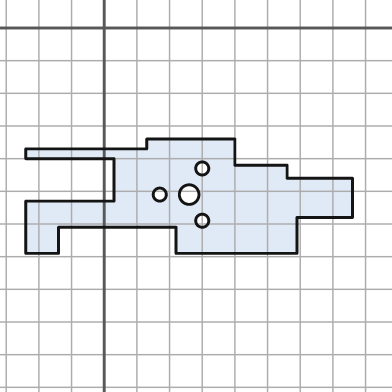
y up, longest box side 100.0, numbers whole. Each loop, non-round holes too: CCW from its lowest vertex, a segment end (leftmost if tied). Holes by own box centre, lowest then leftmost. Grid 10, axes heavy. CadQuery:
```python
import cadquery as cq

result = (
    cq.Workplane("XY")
    .moveTo(-24.0, -69.0)
    .lineTo(-14.0, -69.0)
    .lineTo(-14.0, -61.0)
    .lineTo(22.0, -61.0)
    .lineTo(22.0, -69.0)
    .lineTo(59.0, -69.0)
    .lineTo(59.0, -58.0)
    .lineTo(76.0, -58.0)
    .lineTo(76.0, -46.0)
    .lineTo(56.0, -46.0)
    .lineTo(56.0, -42.0)
    .lineTo(40.0, -42.0)
    .lineTo(40.0, -34.0)
    .lineTo(13.0, -34.0)
    .lineTo(13.0, -37.0)
    .lineTo(-24.0, -37.0)
    .lineTo(-24.0, -40.0)
    .lineTo(3.0, -40.0)
    .lineTo(3.0, -53.0)
    .lineTo(-24.0, -53.0)
    .close()
    .moveTo(30.0, -59.0)
    .circle(2.0)
    .moveTo(17.0, -51.0)
    .circle(2.0)
    .moveTo(26.0, -51.0)
    .circle(3.0)
    .moveTo(30.0, -43.0)
    .circle(2.0)
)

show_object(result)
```